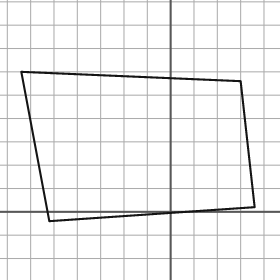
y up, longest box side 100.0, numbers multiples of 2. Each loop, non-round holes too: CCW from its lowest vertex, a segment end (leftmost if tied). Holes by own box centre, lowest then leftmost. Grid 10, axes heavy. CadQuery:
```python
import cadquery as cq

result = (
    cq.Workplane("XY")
    .moveTo(-52.0, -4.0)
    .lineTo(36.0, 2.0)
    .lineTo(30.0, 56.0)
    .lineTo(-64.0, 60.0)
    .close()
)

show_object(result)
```